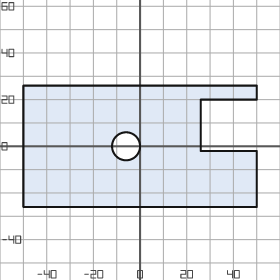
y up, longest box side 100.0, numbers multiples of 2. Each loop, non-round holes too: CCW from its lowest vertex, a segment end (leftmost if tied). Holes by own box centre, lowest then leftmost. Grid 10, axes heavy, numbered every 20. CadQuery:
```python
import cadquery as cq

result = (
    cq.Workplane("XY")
    .moveTo(-50.0, -26.0)
    .lineTo(50.0, -26.0)
    .lineTo(50.0, -2.0)
    .lineTo(26.0, -2.0)
    .lineTo(26.0, 20.0)
    .lineTo(50.0, 20.0)
    .lineTo(50.0, 26.0)
    .lineTo(-50.0, 26.0)
    .close()
    .moveTo(-6.0, 0.0)
    .circle(6.0)
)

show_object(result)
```